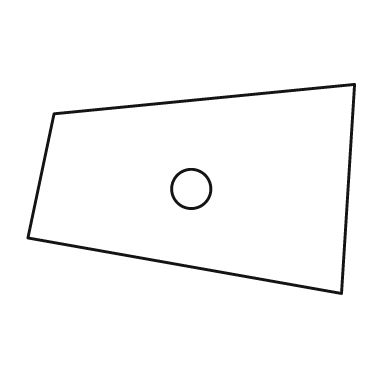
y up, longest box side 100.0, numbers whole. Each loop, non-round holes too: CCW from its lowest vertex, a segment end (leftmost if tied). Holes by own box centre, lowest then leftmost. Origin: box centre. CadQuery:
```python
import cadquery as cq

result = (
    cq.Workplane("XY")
    .moveTo(46.0, -32.0)
    .lineTo(50.0, 32.0)
    .lineTo(-42.0, 23.0)
    .lineTo(-50.0, -15.0)
    .close()
    .moveTo(0.0, 0.0)
    .circle(6.0)
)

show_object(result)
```